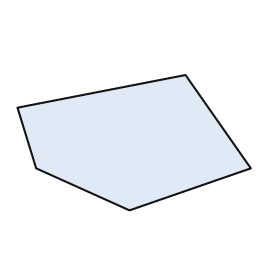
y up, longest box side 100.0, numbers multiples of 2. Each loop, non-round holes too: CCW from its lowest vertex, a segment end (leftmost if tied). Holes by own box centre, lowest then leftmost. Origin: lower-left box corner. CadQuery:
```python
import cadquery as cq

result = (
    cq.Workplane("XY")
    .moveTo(48.0, 0.0)
    .lineTo(100.0, 18.0)
    .lineTo(72.0, 58.0)
    .lineTo(0.0, 44.0)
    .lineTo(8.0, 18.0)
    .close()
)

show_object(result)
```